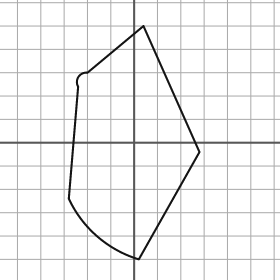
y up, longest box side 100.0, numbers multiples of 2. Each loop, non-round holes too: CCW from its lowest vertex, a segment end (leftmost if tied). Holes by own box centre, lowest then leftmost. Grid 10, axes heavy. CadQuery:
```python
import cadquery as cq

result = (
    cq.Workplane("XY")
    .moveTo(2.0, -50.0)
    .lineTo(28.0, -4.0)
    .lineTo(4.0, 50.0)
    .lineTo(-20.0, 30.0)
    .threePointArc((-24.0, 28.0), (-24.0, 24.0))
    .lineTo(-28.0, -24.0)
    .threePointArc((-16.0, -40.0), (2.0, -50.0))
    .close()
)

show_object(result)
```